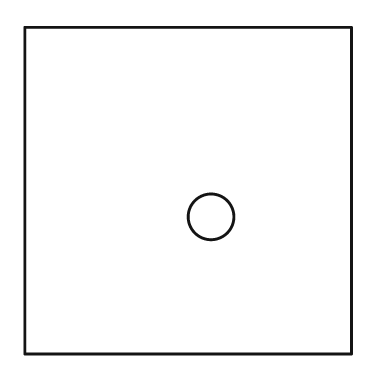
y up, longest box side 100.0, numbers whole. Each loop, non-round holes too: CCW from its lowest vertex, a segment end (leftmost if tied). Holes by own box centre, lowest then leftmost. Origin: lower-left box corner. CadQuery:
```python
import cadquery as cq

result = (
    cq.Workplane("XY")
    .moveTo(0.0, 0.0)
    .lineTo(100.0, 0.0)
    .lineTo(100.0, 100.0)
    .lineTo(0.0, 100.0)
    .close()
    .moveTo(57.0, 42.0)
    .circle(7.0)
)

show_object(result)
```